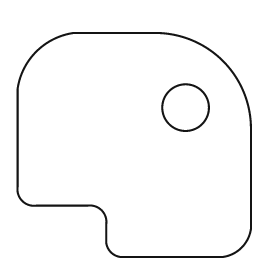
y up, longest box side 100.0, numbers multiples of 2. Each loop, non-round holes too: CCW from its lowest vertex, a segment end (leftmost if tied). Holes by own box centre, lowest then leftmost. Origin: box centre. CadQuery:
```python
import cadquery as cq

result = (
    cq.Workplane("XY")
    .moveTo(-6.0, -48.0)
    .lineTo(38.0, -48.0)
    .threePointArc((46.0, -44.0), (50.0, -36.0))
    .lineTo(50.0, 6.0)
    .threePointArc((38.0, 36.0), (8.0, 48.0))
    .lineTo(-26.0, 48.0)
    .threePointArc((-42.0, 40.0), (-50.0, 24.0))
    .lineTo(-50.0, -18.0)
    .threePointArc((-48.0, -24.0), (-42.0, -26.0))
    .lineTo(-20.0, -26.0)
    .threePointArc((-14.0, -28.0), (-12.0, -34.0))
    .lineTo(-12.0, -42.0)
    .threePointArc((-10.0, -46.0), (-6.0, -48.0))
    .close()
    .moveTo(22.0, 16.0)
    .circle(10.0)
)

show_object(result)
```